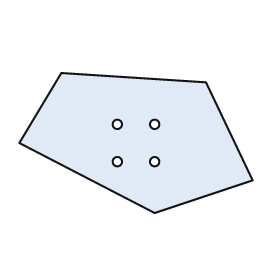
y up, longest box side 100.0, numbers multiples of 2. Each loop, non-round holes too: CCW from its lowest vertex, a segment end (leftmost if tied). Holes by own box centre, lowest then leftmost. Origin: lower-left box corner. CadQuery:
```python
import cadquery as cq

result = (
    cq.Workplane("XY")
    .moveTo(58.0, 0.0)
    .lineTo(100.0, 14.0)
    .lineTo(80.0, 56.0)
    .lineTo(18.0, 60.0)
    .lineTo(0.0, 30.0)
    .close()
    .moveTo(42.0, 22.0)
    .circle(2.0)
    .moveTo(58.0, 22.0)
    .circle(2.0)
    .moveTo(42.0, 38.0)
    .circle(2.0)
    .moveTo(58.0, 38.0)
    .circle(2.0)
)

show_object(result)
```